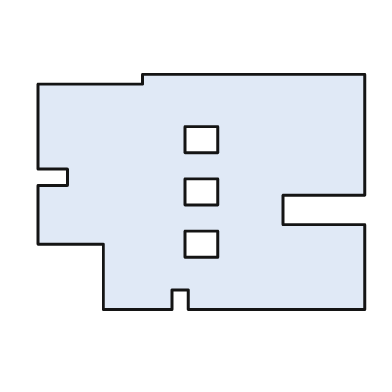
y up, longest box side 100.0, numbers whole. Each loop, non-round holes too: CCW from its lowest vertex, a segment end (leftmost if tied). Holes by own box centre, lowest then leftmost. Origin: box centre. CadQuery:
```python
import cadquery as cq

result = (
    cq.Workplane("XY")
    .moveTo(-30.0, -36.0)
    .lineTo(-9.0, -36.0)
    .lineTo(-9.0, -30.0)
    .lineTo(-4.0, -30.0)
    .lineTo(-4.0, -36.0)
    .lineTo(50.0, -36.0)
    .lineTo(50.0, -10.0)
    .lineTo(25.0, -10.0)
    .lineTo(25.0, -1.0)
    .lineTo(50.0, -1.0)
    .lineTo(50.0, 36.0)
    .lineTo(-18.0, 36.0)
    .lineTo(-18.0, 33.0)
    .lineTo(-50.0, 33.0)
    .lineTo(-50.0, 7.0)
    .lineTo(-41.0, 7.0)
    .lineTo(-41.0, 2.0)
    .lineTo(-50.0, 2.0)
    .lineTo(-50.0, -16.0)
    .lineTo(-30.0, -16.0)
    .close()
    .moveTo(-5.0, -20.0)
    .lineTo(5.0, -20.0)
    .lineTo(5.0, -12.0)
    .lineTo(-5.0, -12.0)
    .close()
    .moveTo(-5.0, -4.0)
    .lineTo(5.0, -4.0)
    .lineTo(5.0, 4.0)
    .lineTo(-5.0, 4.0)
    .close()
    .moveTo(-5.0, 12.0)
    .lineTo(5.0, 12.0)
    .lineTo(5.0, 20.0)
    .lineTo(-5.0, 20.0)
    .close()
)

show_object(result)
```